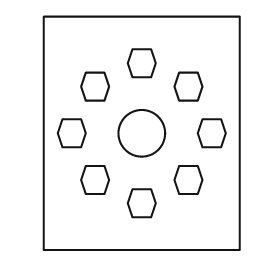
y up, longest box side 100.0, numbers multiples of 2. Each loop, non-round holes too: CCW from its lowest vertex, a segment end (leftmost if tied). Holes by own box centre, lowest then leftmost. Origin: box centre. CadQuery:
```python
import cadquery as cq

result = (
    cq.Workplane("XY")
    .moveTo(-42.0, -50.0)
    .lineTo(42.0, -50.0)
    .lineTo(42.0, 50.0)
    .lineTo(-42.0, 50.0)
    .close()
    .moveTo(-4.0, -36.0)
    .lineTo(4.0, -36.0)
    .lineTo(6.0, -30.0)
    .lineTo(4.0, -24.0)
    .lineTo(-4.0, -24.0)
    .lineTo(-6.0, -30.0)
    .close()
    .moveTo(-24.0, -26.0)
    .lineTo(-16.0, -26.0)
    .lineTo(-14.0, -20.0)
    .lineTo(-16.0, -14.0)
    .lineTo(-24.0, -14.0)
    .lineTo(-26.0, -20.0)
    .close()
    .moveTo(16.0, -26.0)
    .lineTo(24.0, -26.0)
    .lineTo(26.0, -20.0)
    .lineTo(24.0, -14.0)
    .lineTo(16.0, -14.0)
    .lineTo(14.0, -20.0)
    .close()
    .moveTo(-34.0, -6.0)
    .lineTo(-26.0, -6.0)
    .lineTo(-24.0, 0.0)
    .lineTo(-26.0, 6.0)
    .lineTo(-34.0, 6.0)
    .lineTo(-36.0, 0.0)
    .close()
    .moveTo(0.0, 0.0)
    .circle(10.0)
    .moveTo(26.0, -6.0)
    .lineTo(34.0, -6.0)
    .lineTo(36.0, 0.0)
    .lineTo(34.0, 6.0)
    .lineTo(26.0, 6.0)
    .lineTo(24.0, 0.0)
    .close()
    .moveTo(-24.0, 14.0)
    .lineTo(-16.0, 14.0)
    .lineTo(-14.0, 20.0)
    .lineTo(-16.0, 26.0)
    .lineTo(-24.0, 26.0)
    .lineTo(-26.0, 20.0)
    .close()
    .moveTo(16.0, 14.0)
    .lineTo(24.0, 14.0)
    .lineTo(26.0, 20.0)
    .lineTo(24.0, 26.0)
    .lineTo(16.0, 26.0)
    .lineTo(14.0, 20.0)
    .close()
    .moveTo(-4.0, 24.0)
    .lineTo(4.0, 24.0)
    .lineTo(6.0, 30.0)
    .lineTo(4.0, 36.0)
    .lineTo(-4.0, 36.0)
    .lineTo(-6.0, 30.0)
    .close()
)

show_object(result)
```